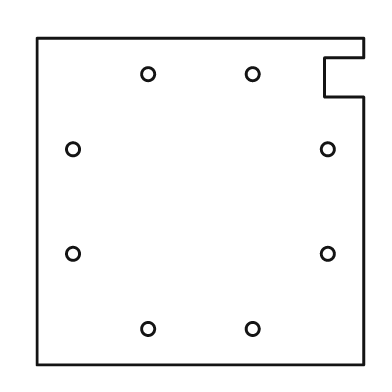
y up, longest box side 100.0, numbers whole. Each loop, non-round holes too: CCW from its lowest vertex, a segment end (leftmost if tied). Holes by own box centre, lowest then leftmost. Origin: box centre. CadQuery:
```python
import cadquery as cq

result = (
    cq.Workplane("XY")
    .moveTo(-50.0, -50.0)
    .lineTo(50.0, -50.0)
    .lineTo(50.0, 32.0)
    .lineTo(38.0, 32.0)
    .lineTo(38.0, 44.0)
    .lineTo(50.0, 44.0)
    .lineTo(50.0, 50.0)
    .lineTo(-50.0, 50.0)
    .close()
    .moveTo(-16.0, -39.0)
    .circle(2.0)
    .moveTo(16.0, -39.0)
    .circle(2.0)
    .moveTo(-39.0, -16.0)
    .circle(2.0)
    .moveTo(39.0, -16.0)
    .circle(2.0)
    .moveTo(-39.0, 16.0)
    .circle(2.0)
    .moveTo(39.0, 16.0)
    .circle(2.0)
    .moveTo(-16.0, 39.0)
    .circle(2.0)
    .moveTo(16.0, 39.0)
    .circle(2.0)
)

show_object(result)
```